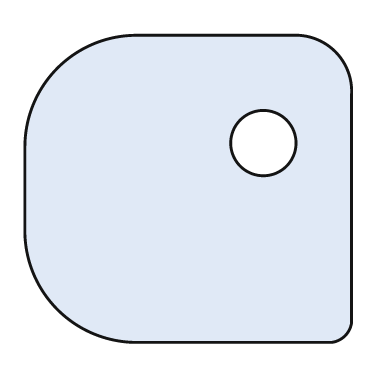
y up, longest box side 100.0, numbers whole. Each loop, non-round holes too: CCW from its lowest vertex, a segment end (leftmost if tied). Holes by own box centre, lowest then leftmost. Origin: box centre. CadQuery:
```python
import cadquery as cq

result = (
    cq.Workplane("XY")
    .moveTo(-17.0, -47.0)
    .lineTo(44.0, -47.0)
    .threePointArc((48.0, -45.0), (50.0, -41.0))
    .lineTo(50.0, 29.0)
    .threePointArc((45.0, 42.0), (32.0, 47.0))
    .lineTo(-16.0, 47.0)
    .threePointArc((-40.0, 37.0), (-50.0, 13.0))
    .lineTo(-50.0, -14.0)
    .threePointArc((-40.0, -37.0), (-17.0, -47.0))
    .close()
    .moveTo(23.0, 14.0)
    .circle(10.0)
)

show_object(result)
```